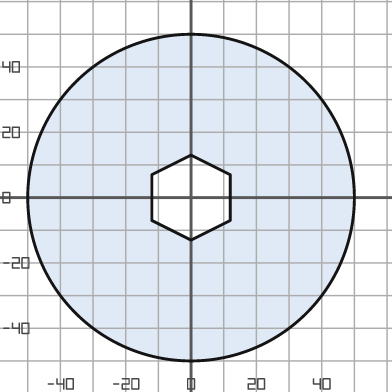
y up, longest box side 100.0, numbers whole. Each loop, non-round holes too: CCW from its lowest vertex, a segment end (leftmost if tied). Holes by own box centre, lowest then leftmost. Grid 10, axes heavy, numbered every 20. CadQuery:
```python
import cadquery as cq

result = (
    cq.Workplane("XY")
    .moveTo(0.0, 0.0)
    .circle(50.0)
    .moveTo(0.0, -13.0)
    .lineTo(12.0, -7.0)
    .lineTo(12.0, 7.0)
    .lineTo(0.0, 13.0)
    .lineTo(-12.0, 7.0)
    .lineTo(-12.0, -7.0)
    .close()
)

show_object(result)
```